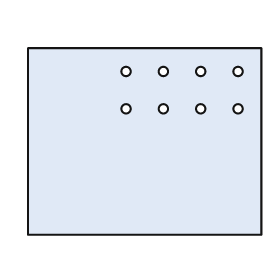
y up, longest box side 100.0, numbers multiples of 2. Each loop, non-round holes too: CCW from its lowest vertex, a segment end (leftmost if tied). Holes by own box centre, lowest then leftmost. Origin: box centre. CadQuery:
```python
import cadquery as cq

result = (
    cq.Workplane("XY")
    .moveTo(-50.0, -40.0)
    .lineTo(50.0, -40.0)
    .lineTo(50.0, 40.0)
    .lineTo(-50.0, 40.0)
    .close()
    .moveTo(-8.0, 14.0)
    .circle(2.0)
    .moveTo(8.0, 14.0)
    .circle(2.0)
    .moveTo(24.0, 14.0)
    .circle(2.0)
    .moveTo(40.0, 14.0)
    .circle(2.0)
    .moveTo(-8.0, 30.0)
    .circle(2.0)
    .moveTo(8.0, 30.0)
    .circle(2.0)
    .moveTo(24.0, 30.0)
    .circle(2.0)
    .moveTo(40.0, 30.0)
    .circle(2.0)
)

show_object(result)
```